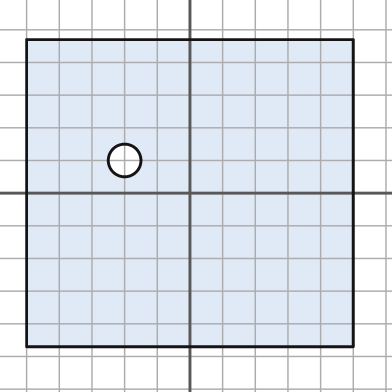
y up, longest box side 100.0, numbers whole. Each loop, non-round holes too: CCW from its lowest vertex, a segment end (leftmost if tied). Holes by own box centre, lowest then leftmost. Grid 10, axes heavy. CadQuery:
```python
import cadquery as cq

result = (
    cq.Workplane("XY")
    .moveTo(-50.0, -47.0)
    .lineTo(50.0, -47.0)
    .lineTo(50.0, 47.0)
    .lineTo(-50.0, 47.0)
    .close()
    .moveTo(-20.0, 10.0)
    .circle(5.0)
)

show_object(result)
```